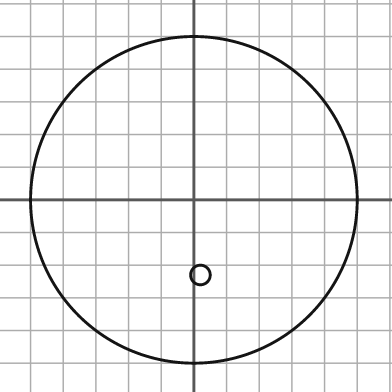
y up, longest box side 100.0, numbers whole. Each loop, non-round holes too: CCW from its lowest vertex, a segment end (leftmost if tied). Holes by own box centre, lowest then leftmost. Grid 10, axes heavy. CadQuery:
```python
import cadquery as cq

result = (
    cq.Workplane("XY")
    .moveTo(0.0, 0.0)
    .circle(50.0)
    .moveTo(2.0, -23.0)
    .circle(3.0)
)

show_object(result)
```